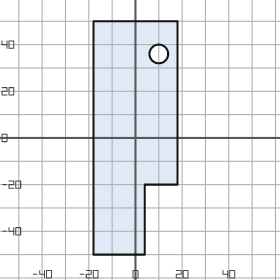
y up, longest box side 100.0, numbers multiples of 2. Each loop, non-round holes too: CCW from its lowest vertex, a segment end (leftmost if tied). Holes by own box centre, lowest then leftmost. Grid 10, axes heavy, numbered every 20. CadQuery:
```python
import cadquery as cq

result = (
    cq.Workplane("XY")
    .moveTo(-18.0, -50.0)
    .lineTo(4.0, -50.0)
    .lineTo(4.0, -20.0)
    .lineTo(18.0, -20.0)
    .lineTo(18.0, 50.0)
    .lineTo(-18.0, 50.0)
    .close()
    .moveTo(10.0, 36.0)
    .circle(4.0)
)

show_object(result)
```